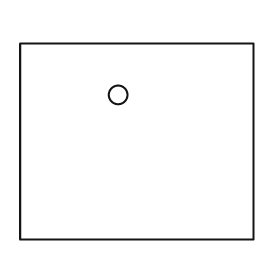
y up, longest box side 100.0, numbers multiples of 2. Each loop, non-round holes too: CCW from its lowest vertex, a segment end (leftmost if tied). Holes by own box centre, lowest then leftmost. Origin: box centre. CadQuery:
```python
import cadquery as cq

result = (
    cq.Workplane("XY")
    .moveTo(-50.0, -42.0)
    .lineTo(50.0, -42.0)
    .lineTo(50.0, 42.0)
    .lineTo(-50.0, 42.0)
    .close()
    .moveTo(-8.0, 20.0)
    .circle(4.0)
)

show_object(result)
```